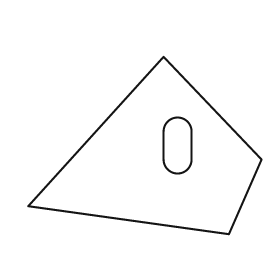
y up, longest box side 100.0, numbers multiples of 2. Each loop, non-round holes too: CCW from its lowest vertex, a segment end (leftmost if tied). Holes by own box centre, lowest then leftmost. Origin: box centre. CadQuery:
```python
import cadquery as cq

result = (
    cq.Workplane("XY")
    .moveTo(36.0, -38.0)
    .lineTo(50.0, -6.0)
    .lineTo(8.0, 38.0)
    .lineTo(-50.0, -26.0)
    .close()
    .moveTo(8.0, -6.0)
    .threePointArc((14.0, -12.0), (20.0, -6.0))
    .lineTo(20.0, 6.0)
    .threePointArc((14.0, 12.0), (8.0, 6.0))
    .close()
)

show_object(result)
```